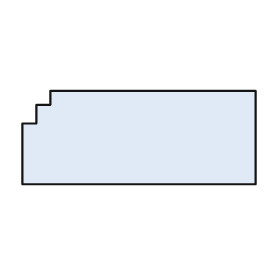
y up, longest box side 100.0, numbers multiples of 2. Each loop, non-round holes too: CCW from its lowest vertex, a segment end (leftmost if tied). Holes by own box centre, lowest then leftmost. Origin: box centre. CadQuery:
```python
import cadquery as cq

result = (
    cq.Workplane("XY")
    .moveTo(-50.0, -20.0)
    .lineTo(50.0, -20.0)
    .lineTo(50.0, 20.0)
    .lineTo(-38.0, 20.0)
    .lineTo(-38.0, 14.0)
    .lineTo(-44.0, 14.0)
    .lineTo(-44.0, 6.0)
    .lineTo(-50.0, 6.0)
    .close()
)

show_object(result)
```